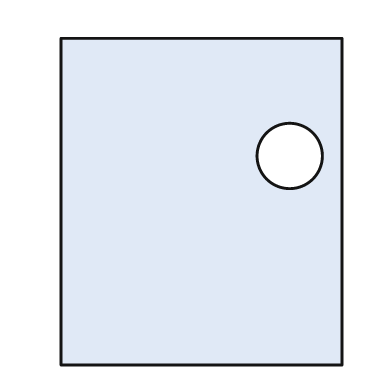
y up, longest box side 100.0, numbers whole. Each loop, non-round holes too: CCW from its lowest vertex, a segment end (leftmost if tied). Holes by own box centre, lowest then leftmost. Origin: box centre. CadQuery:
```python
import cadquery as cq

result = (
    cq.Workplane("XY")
    .moveTo(-43.0, -50.0)
    .lineTo(43.0, -50.0)
    .lineTo(43.0, 50.0)
    .lineTo(-43.0, 50.0)
    .close()
    .moveTo(27.0, 14.0)
    .circle(10.0)
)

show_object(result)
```